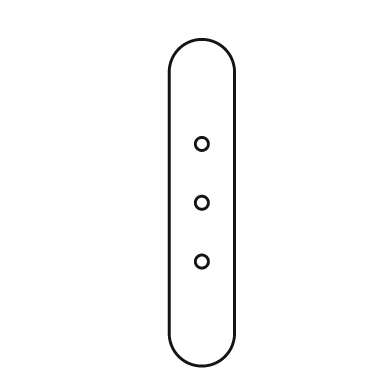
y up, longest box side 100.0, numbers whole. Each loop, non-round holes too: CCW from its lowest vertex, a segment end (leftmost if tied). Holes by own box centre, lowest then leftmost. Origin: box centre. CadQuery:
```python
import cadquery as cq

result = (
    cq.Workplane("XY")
    .moveTo(-10.0, -40.0)
    .threePointArc((0.0, -50.0), (10.0, -40.0))
    .lineTo(10.0, 40.0)
    .threePointArc((0.0, 50.0), (-10.0, 40.0))
    .close()
    .moveTo(0.0, -18.0)
    .circle(2.0)
    .moveTo(0.0, 0.0)
    .circle(2.0)
    .moveTo(0.0, 18.0)
    .circle(2.0)
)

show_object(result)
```